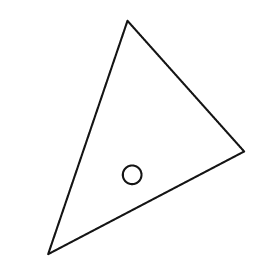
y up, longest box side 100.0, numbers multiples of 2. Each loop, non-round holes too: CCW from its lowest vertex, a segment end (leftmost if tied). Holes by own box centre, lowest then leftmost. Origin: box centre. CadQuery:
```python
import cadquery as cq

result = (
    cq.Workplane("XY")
    .moveTo(-42.0, -50.0)
    .lineTo(42.0, -6.0)
    .lineTo(-8.0, 50.0)
    .close()
    .moveTo(-6.0, -16.0)
    .circle(4.0)
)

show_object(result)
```